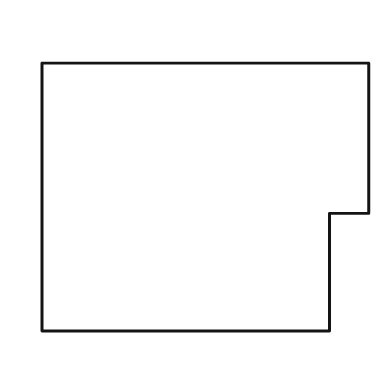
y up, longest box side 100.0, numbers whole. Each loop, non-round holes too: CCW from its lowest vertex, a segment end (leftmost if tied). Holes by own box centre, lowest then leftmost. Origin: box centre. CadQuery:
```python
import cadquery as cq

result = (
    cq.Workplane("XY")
    .moveTo(-50.0, -41.0)
    .lineTo(38.0, -41.0)
    .lineTo(38.0, -5.0)
    .lineTo(50.0, -5.0)
    .lineTo(50.0, 41.0)
    .lineTo(-50.0, 41.0)
    .close()
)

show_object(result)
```